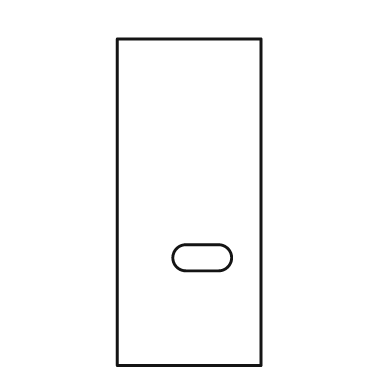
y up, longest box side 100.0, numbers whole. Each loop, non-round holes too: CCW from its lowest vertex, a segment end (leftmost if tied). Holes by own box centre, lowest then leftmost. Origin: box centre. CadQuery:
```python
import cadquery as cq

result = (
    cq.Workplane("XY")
    .moveTo(-22.0, -50.0)
    .lineTo(22.0, -50.0)
    .lineTo(22.0, 50.0)
    .lineTo(-22.0, 50.0)
    .close()
    .moveTo(-1.0, -21.0)
    .lineTo(9.0, -21.0)
    .threePointArc((13.0, -17.0), (9.0, -13.0))
    .lineTo(-1.0, -13.0)
    .threePointArc((-5.0, -17.0), (-1.0, -21.0))
    .close()
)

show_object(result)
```